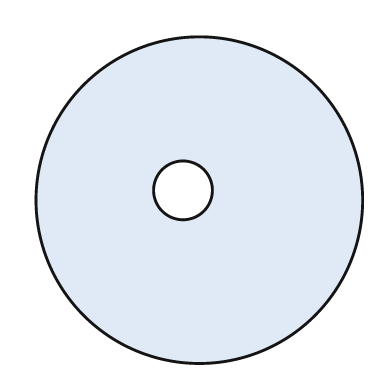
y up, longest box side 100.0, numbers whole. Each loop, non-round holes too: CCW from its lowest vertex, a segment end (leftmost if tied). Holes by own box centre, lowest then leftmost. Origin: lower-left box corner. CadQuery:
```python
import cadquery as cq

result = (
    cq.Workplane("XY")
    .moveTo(50.0, 50.0)
    .circle(50.0)
    .moveTo(45.0, 53.0)
    .circle(9.0)
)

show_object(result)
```